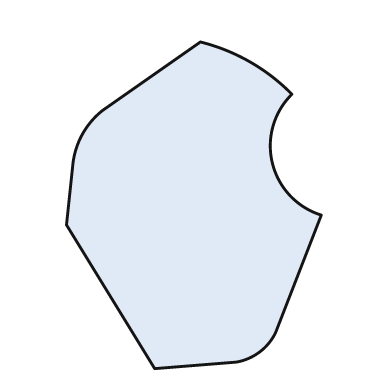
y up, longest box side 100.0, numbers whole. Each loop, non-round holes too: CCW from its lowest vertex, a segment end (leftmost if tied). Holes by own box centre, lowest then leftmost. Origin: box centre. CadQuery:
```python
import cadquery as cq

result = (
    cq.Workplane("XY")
    .moveTo(-12.0, -50.0)
    .lineTo(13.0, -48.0)
    .threePointArc((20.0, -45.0), (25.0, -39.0))
    .lineTo(39.0, -3.0)
    .threePointArc((24.0, 13.0), (30.0, 34.0))
    .threePointArc((17.0, 44.0), (2.0, 50.0))
    .lineTo(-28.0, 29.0)
    .threePointArc((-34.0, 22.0), (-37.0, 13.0))
    .lineTo(-39.0, -6.0)
    .close()
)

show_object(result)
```